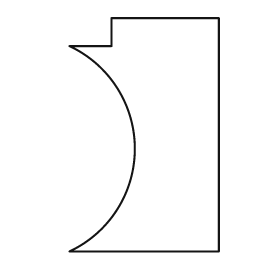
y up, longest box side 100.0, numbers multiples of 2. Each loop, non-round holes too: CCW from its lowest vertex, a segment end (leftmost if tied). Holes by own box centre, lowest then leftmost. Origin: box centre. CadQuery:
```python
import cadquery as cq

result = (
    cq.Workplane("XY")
    .moveTo(-32.0, -50.0)
    .lineTo(32.0, -50.0)
    .lineTo(32.0, 50.0)
    .lineTo(-14.0, 50.0)
    .lineTo(-14.0, 38.0)
    .lineTo(-32.0, 38.0)
    .threePointArc((-4.0, -6.0), (-32.0, -50.0))
    .close()
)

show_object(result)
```